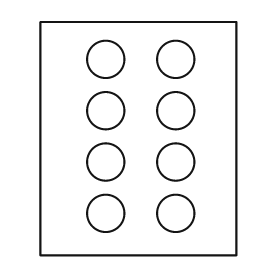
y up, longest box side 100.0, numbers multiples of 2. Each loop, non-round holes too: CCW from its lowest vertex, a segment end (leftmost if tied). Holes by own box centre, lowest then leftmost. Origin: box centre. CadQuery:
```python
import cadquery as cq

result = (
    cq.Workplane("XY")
    .moveTo(-42.0, -50.0)
    .lineTo(42.0, -50.0)
    .lineTo(42.0, 50.0)
    .lineTo(-42.0, 50.0)
    .close()
    .moveTo(-14.0, -32.0)
    .circle(8.0)
    .moveTo(16.0, -32.0)
    .circle(8.0)
    .moveTo(-14.0, -10.0)
    .circle(8.0)
    .moveTo(16.0, -10.0)
    .circle(8.0)
    .moveTo(-14.0, 12.0)
    .circle(8.0)
    .moveTo(16.0, 12.0)
    .circle(8.0)
    .moveTo(-14.0, 34.0)
    .circle(8.0)
    .moveTo(16.0, 34.0)
    .circle(8.0)
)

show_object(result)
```